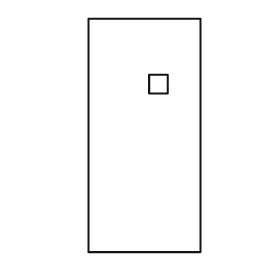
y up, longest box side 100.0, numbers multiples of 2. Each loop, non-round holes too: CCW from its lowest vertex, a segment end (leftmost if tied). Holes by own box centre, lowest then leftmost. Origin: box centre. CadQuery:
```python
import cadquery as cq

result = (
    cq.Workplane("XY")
    .moveTo(-24.0, -50.0)
    .lineTo(24.0, -50.0)
    .lineTo(24.0, 50.0)
    .lineTo(-24.0, 50.0)
    .close()
    .moveTo(2.0, 18.0)
    .lineTo(10.0, 18.0)
    .lineTo(10.0, 26.0)
    .lineTo(2.0, 26.0)
    .close()
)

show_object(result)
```